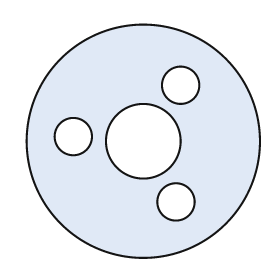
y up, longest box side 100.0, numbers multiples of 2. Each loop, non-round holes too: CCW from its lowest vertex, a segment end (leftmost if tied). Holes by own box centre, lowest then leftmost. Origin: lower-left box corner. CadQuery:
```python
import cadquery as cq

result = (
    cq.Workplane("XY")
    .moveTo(50.0, 50.0)
    .circle(50.0)
    .moveTo(64.0, 24.0)
    .circle(8.0)
    .moveTo(50.0, 50.0)
    .circle(16.0)
    .moveTo(20.0, 52.0)
    .circle(8.0)
    .moveTo(66.0, 74.0)
    .circle(8.0)
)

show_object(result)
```